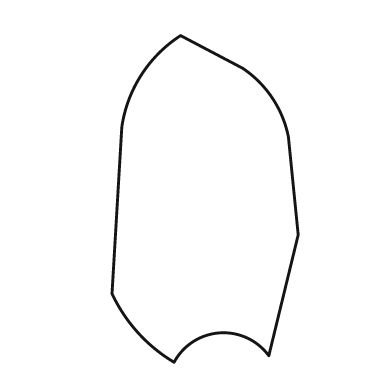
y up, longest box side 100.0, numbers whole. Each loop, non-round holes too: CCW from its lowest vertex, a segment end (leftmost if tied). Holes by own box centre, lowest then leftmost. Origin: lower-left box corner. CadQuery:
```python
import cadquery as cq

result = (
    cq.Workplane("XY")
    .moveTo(19.0, 0.0)
    .threePointArc((33.0, 9.0), (48.0, 2.0))
    .lineTo(57.0, 39.0)
    .lineTo(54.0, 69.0)
    .threePointArc((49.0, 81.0), (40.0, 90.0))
    .lineTo(21.0, 100.0)
    .threePointArc((9.0, 88.0), (3.0, 72.0))
    .lineTo(0.0, 21.0)
    .threePointArc((8.0, 9.0), (19.0, 0.0))
    .close()
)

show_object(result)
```